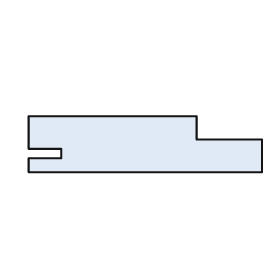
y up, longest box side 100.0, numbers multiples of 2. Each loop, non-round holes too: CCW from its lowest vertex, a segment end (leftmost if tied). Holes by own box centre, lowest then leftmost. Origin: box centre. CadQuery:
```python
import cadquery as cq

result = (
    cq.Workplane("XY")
    .moveTo(-50.0, -12.0)
    .lineTo(50.0, -12.0)
    .lineTo(50.0, 2.0)
    .lineTo(22.0, 2.0)
    .lineTo(22.0, 12.0)
    .lineTo(-50.0, 12.0)
    .lineTo(-50.0, -2.0)
    .lineTo(-36.0, -2.0)
    .lineTo(-36.0, -6.0)
    .lineTo(-50.0, -6.0)
    .close()
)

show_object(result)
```